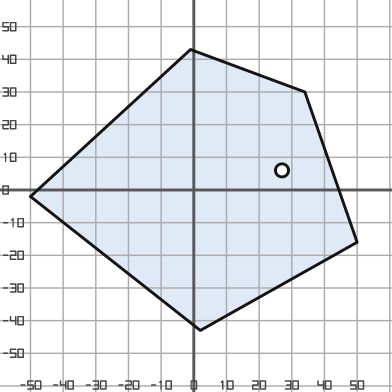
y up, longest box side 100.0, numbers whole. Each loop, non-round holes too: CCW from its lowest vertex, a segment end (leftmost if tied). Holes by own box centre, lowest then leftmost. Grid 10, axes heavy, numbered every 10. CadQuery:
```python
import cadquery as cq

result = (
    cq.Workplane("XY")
    .moveTo(2.0, -43.0)
    .lineTo(50.0, -16.0)
    .lineTo(34.0, 30.0)
    .lineTo(-1.0, 43.0)
    .lineTo(-50.0, -2.0)
    .close()
    .moveTo(27.0, 6.0)
    .circle(2.0)
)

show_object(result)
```